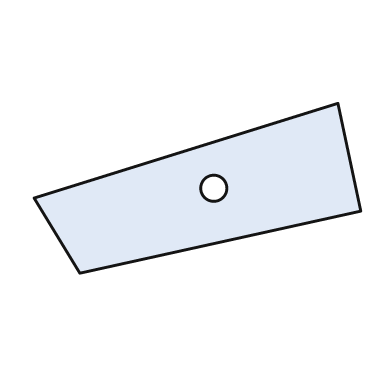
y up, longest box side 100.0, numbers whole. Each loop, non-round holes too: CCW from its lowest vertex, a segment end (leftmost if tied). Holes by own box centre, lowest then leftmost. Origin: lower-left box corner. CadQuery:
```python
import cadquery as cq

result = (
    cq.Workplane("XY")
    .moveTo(14.0, 0.0)
    .lineTo(100.0, 19.0)
    .lineTo(93.0, 52.0)
    .lineTo(0.0, 23.0)
    .close()
    .moveTo(55.0, 26.0)
    .circle(4.0)
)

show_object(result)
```